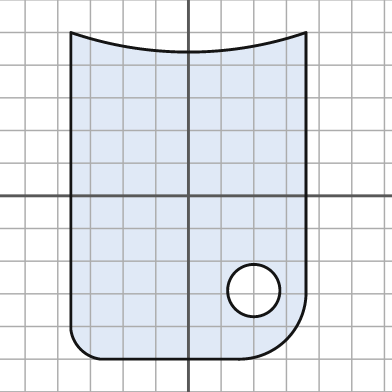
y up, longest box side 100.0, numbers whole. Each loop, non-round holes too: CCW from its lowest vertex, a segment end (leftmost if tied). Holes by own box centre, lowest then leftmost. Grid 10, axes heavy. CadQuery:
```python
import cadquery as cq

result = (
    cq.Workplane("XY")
    .moveTo(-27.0, -50.0)
    .lineTo(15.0, -50.0)
    .threePointArc((30.0, -44.0), (36.0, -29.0))
    .lineTo(36.0, 50.0)
    .threePointArc((0.0, 44.0), (-36.0, 50.0))
    .lineTo(-36.0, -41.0)
    .threePointArc((-33.0, -47.0), (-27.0, -50.0))
    .close()
    .moveTo(20.0, -29.0)
    .circle(8.0)
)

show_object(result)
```